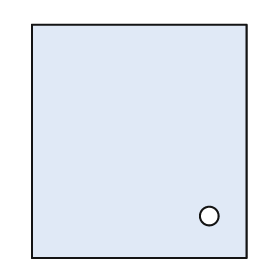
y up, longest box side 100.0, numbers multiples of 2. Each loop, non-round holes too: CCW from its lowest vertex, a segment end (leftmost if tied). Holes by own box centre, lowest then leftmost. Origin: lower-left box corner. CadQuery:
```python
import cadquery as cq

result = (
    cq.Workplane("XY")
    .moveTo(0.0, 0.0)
    .lineTo(92.0, 0.0)
    .lineTo(92.0, 100.0)
    .lineTo(0.0, 100.0)
    .close()
    .moveTo(76.0, 18.0)
    .circle(4.0)
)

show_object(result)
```